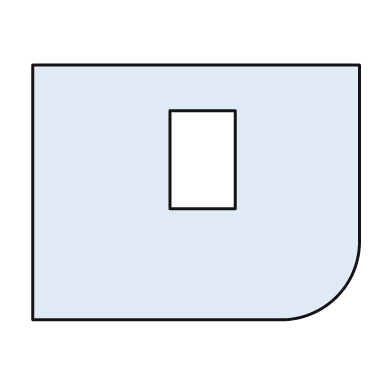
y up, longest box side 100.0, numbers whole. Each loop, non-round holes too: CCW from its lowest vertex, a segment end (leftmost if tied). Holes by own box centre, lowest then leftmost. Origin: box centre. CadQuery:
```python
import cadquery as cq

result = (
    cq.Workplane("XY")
    .moveTo(-50.0, -39.0)
    .lineTo(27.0, -39.0)
    .threePointArc((43.0, -32.0), (50.0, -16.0))
    .lineTo(50.0, 39.0)
    .lineTo(-50.0, 39.0)
    .close()
    .moveTo(-8.0, -5.0)
    .lineTo(12.0, -5.0)
    .lineTo(12.0, 25.0)
    .lineTo(-8.0, 25.0)
    .close()
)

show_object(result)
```